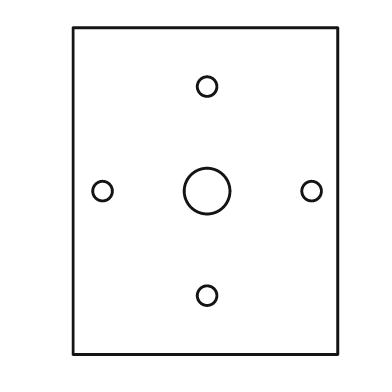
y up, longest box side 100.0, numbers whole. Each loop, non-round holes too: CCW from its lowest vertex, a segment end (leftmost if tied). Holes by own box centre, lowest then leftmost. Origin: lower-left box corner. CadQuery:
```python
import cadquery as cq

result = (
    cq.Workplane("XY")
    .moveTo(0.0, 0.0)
    .lineTo(81.0, 0.0)
    .lineTo(81.0, 100.0)
    .lineTo(0.0, 100.0)
    .close()
    .moveTo(41.0, 18.0)
    .circle(3.0)
    .moveTo(9.0, 50.0)
    .circle(3.0)
    .moveTo(41.0, 50.0)
    .circle(7.0)
    .moveTo(73.0, 50.0)
    .circle(3.0)
    .moveTo(41.0, 82.0)
    .circle(3.0)
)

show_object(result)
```